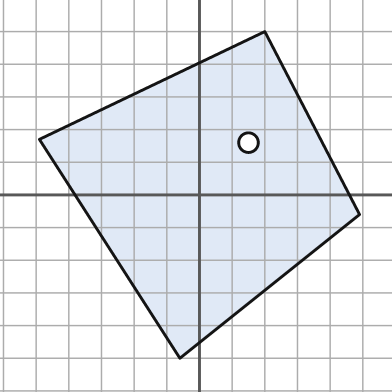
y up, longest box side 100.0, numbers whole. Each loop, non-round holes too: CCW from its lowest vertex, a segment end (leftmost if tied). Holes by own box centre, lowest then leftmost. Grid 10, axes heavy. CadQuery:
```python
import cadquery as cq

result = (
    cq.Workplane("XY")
    .moveTo(-6.0, -50.0)
    .lineTo(49.0, -6.0)
    .lineTo(20.0, 50.0)
    .lineTo(-49.0, 17.0)
    .close()
    .moveTo(15.0, 16.0)
    .circle(3.0)
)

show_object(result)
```